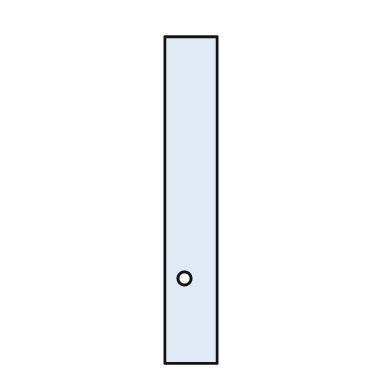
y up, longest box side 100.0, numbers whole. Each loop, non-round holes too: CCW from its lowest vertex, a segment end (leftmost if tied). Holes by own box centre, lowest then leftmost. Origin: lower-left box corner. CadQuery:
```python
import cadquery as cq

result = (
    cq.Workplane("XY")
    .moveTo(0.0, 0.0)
    .lineTo(16.0, 0.0)
    .lineTo(16.0, 100.0)
    .lineTo(0.0, 100.0)
    .close()
    .moveTo(6.0, 26.0)
    .circle(2.0)
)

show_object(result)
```